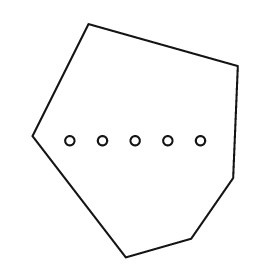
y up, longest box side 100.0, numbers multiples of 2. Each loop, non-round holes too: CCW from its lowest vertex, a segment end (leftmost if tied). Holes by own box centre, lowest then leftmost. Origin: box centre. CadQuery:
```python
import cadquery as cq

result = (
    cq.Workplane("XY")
    .moveTo(-4.0, -50.0)
    .lineTo(24.0, -42.0)
    .lineTo(42.0, -16.0)
    .lineTo(44.0, 32.0)
    .lineTo(-20.0, 50.0)
    .lineTo(-44.0, 2.0)
    .close()
    .moveTo(-28.0, 0.0)
    .circle(2.0)
    .moveTo(-14.0, 0.0)
    .circle(2.0)
    .moveTo(0.0, 0.0)
    .circle(2.0)
    .moveTo(14.0, 0.0)
    .circle(2.0)
    .moveTo(28.0, 0.0)
    .circle(2.0)
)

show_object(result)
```